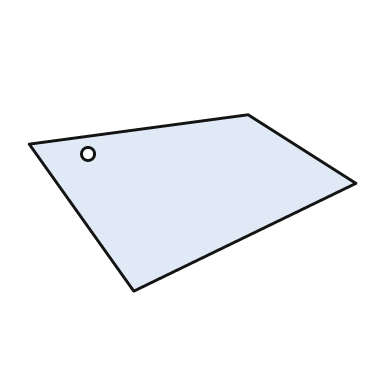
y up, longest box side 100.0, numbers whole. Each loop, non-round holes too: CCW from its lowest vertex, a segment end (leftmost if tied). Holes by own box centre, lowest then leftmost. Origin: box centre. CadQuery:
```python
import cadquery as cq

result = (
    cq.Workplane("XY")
    .moveTo(-18.0, -27.0)
    .lineTo(50.0, 6.0)
    .lineTo(17.0, 27.0)
    .lineTo(-50.0, 18.0)
    .close()
    .moveTo(-32.0, 15.0)
    .circle(2.0)
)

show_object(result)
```